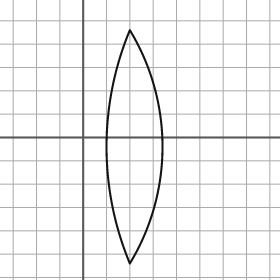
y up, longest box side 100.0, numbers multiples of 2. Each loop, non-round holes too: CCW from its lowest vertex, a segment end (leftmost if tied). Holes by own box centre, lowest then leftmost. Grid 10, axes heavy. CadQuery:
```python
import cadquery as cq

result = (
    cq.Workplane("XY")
    .moveTo(20.0, -54.0)
    .threePointArc((34.0, -4.0), (20.0, 46.0))
    .threePointArc((10.0, -4.0), (20.0, -54.0))
    .close()
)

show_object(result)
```